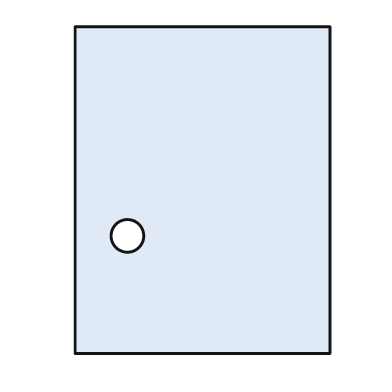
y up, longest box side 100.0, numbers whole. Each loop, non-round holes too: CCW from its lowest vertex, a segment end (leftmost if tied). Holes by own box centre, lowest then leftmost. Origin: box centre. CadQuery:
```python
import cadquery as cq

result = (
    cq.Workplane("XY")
    .moveTo(-39.0, -50.0)
    .lineTo(39.0, -50.0)
    .lineTo(39.0, 50.0)
    .lineTo(-39.0, 50.0)
    .close()
    .moveTo(-23.0, -14.0)
    .circle(5.0)
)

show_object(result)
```